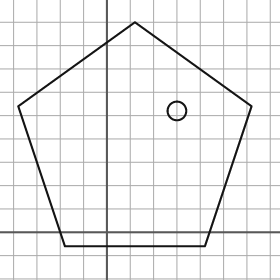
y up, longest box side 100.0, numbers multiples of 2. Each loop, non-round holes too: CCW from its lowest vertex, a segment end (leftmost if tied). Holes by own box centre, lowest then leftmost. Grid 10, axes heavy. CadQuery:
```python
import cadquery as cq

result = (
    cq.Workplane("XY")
    .moveTo(-18.0, -6.0)
    .lineTo(42.0, -6.0)
    .lineTo(62.0, 54.0)
    .lineTo(12.0, 90.0)
    .lineTo(-38.0, 54.0)
    .close()
    .moveTo(30.0, 52.0)
    .circle(4.0)
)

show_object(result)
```